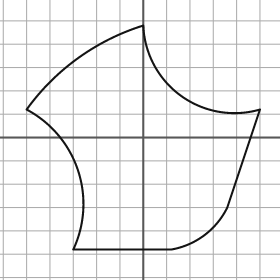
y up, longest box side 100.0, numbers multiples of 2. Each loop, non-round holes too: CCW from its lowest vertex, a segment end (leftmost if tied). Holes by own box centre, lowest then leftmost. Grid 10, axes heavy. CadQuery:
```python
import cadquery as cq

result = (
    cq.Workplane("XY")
    .moveTo(-30.0, -48.0)
    .lineTo(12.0, -48.0)
    .threePointArc((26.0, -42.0), (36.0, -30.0))
    .lineTo(50.0, 12.0)
    .threePointArc((16.0, 18.0), (0.0, 48.0))
    .threePointArc((-28.0, 34.0), (-50.0, 12.0))
    .threePointArc((-28.0, -14.0), (-30.0, -48.0))
    .close()
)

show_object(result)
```